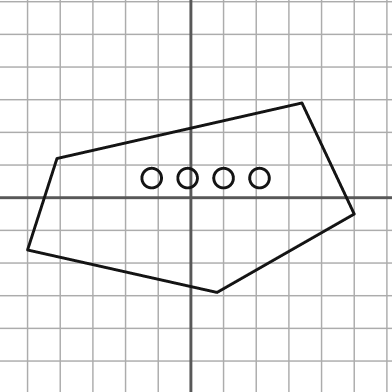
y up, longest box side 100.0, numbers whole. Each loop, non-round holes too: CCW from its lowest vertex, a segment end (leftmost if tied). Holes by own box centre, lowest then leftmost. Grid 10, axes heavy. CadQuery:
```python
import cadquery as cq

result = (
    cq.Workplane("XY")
    .moveTo(8.0, -29.0)
    .lineTo(50.0, -5.0)
    .lineTo(34.0, 29.0)
    .lineTo(-41.0, 12.0)
    .lineTo(-50.0, -16.0)
    .close()
    .moveTo(-12.0, 6.0)
    .circle(3.0)
    .moveTo(-1.0, 6.0)
    .circle(3.0)
    .moveTo(10.0, 6.0)
    .circle(3.0)
    .moveTo(21.0, 6.0)
    .circle(3.0)
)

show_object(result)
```